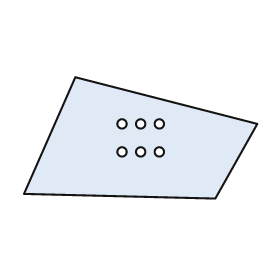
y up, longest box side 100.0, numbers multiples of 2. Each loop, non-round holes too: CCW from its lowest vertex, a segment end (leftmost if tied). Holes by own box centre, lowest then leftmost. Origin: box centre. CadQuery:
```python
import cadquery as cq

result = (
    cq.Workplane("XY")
    .moveTo(32.0, -26.0)
    .lineTo(50.0, 6.0)
    .lineTo(-28.0, 26.0)
    .lineTo(-50.0, -24.0)
    .close()
    .moveTo(-8.0, -6.0)
    .circle(2.0)
    .moveTo(0.0, -6.0)
    .circle(2.0)
    .moveTo(8.0, -6.0)
    .circle(2.0)
    .moveTo(-8.0, 6.0)
    .circle(2.0)
    .moveTo(0.0, 6.0)
    .circle(2.0)
    .moveTo(8.0, 6.0)
    .circle(2.0)
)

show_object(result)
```